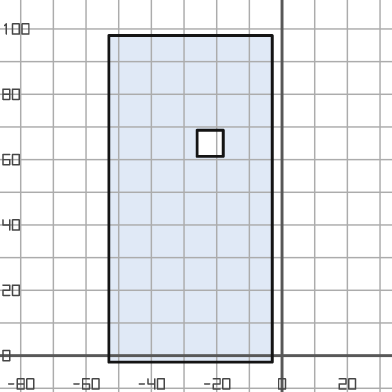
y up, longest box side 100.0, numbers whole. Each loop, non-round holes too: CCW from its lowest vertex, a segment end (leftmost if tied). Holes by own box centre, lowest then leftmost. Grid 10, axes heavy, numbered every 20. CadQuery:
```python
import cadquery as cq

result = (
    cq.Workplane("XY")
    .moveTo(-53.0, -2.0)
    .lineTo(-3.0, -2.0)
    .lineTo(-3.0, 98.0)
    .lineTo(-53.0, 98.0)
    .close()
    .moveTo(-26.0, 61.0)
    .lineTo(-18.0, 61.0)
    .lineTo(-18.0, 69.0)
    .lineTo(-26.0, 69.0)
    .close()
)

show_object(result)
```